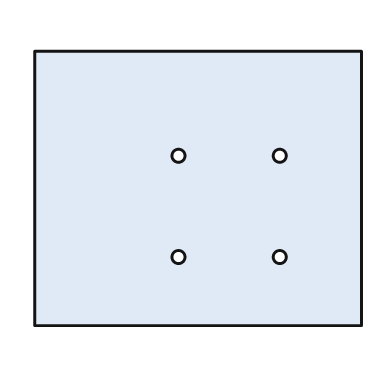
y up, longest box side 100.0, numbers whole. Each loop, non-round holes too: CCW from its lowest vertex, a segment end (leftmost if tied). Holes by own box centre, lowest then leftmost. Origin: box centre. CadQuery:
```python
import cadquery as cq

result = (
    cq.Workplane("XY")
    .moveTo(-50.0, -42.0)
    .lineTo(50.0, -42.0)
    .lineTo(50.0, 42.0)
    .lineTo(-50.0, 42.0)
    .close()
    .moveTo(-6.0, -21.0)
    .circle(2.0)
    .moveTo(25.0, -21.0)
    .circle(2.0)
    .moveTo(-6.0, 10.0)
    .circle(2.0)
    .moveTo(25.0, 10.0)
    .circle(2.0)
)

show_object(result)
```